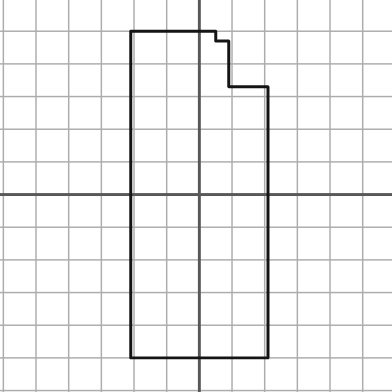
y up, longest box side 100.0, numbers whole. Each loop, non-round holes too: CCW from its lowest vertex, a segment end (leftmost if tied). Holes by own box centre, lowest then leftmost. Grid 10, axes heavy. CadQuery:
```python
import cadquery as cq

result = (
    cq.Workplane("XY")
    .moveTo(-21.0, -50.0)
    .lineTo(21.0, -50.0)
    .lineTo(21.0, 33.0)
    .lineTo(9.0, 33.0)
    .lineTo(9.0, 47.0)
    .lineTo(5.0, 47.0)
    .lineTo(5.0, 50.0)
    .lineTo(-21.0, 50.0)
    .close()
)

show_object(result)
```